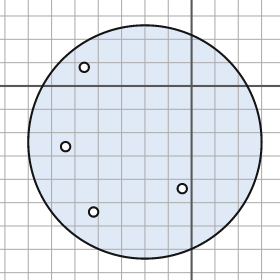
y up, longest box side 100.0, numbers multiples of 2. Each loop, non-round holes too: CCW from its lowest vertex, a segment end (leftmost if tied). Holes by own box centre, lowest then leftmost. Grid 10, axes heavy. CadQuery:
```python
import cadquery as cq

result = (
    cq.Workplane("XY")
    .moveTo(-20.0, -24.0)
    .circle(50.0)
    .moveTo(-42.0, -54.0)
    .circle(2.0)
    .moveTo(-4.0, -44.0)
    .circle(2.0)
    .moveTo(-54.0, -26.0)
    .circle(2.0)
    .moveTo(-46.0, 8.0)
    .circle(2.0)
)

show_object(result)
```